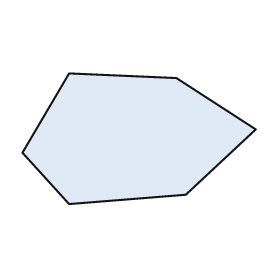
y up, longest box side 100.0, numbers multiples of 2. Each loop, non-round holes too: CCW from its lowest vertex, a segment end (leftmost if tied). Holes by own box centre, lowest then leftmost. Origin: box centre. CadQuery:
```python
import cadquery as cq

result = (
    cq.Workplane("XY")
    .moveTo(-30.0, -28.0)
    .lineTo(20.0, -24.0)
    .lineTo(50.0, 4.0)
    .lineTo(16.0, 26.0)
    .lineTo(-30.0, 28.0)
    .lineTo(-50.0, -6.0)
    .close()
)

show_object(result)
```